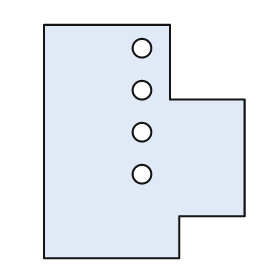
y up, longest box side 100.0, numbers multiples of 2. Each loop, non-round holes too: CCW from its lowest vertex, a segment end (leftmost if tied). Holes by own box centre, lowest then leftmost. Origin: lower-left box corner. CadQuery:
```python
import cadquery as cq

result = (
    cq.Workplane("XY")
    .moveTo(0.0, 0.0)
    .lineTo(58.0, 0.0)
    .lineTo(58.0, 18.0)
    .lineTo(86.0, 18.0)
    .lineTo(86.0, 68.0)
    .lineTo(54.0, 68.0)
    .lineTo(54.0, 100.0)
    .lineTo(0.0, 100.0)
    .close()
    .moveTo(42.0, 36.0)
    .circle(4.0)
    .moveTo(42.0, 54.0)
    .circle(4.0)
    .moveTo(42.0, 72.0)
    .circle(4.0)
    .moveTo(42.0, 90.0)
    .circle(4.0)
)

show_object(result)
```